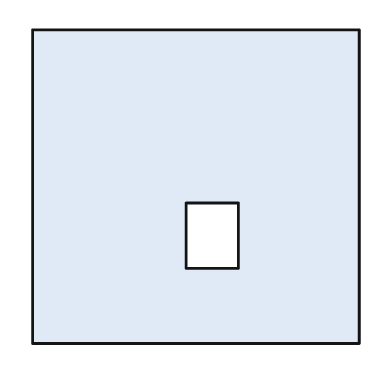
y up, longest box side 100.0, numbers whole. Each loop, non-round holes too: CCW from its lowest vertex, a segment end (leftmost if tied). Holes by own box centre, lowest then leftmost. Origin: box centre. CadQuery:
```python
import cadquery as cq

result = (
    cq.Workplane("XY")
    .moveTo(-50.0, -48.0)
    .lineTo(50.0, -48.0)
    .lineTo(50.0, 48.0)
    .lineTo(-50.0, 48.0)
    .close()
    .moveTo(-3.0, -25.0)
    .lineTo(13.0, -25.0)
    .lineTo(13.0, -5.0)
    .lineTo(-3.0, -5.0)
    .close()
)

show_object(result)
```